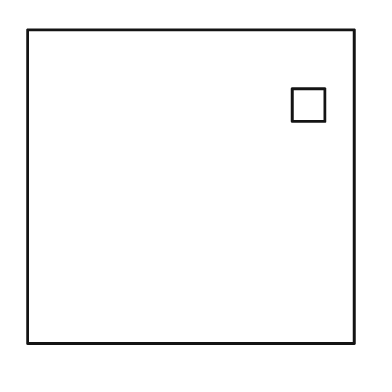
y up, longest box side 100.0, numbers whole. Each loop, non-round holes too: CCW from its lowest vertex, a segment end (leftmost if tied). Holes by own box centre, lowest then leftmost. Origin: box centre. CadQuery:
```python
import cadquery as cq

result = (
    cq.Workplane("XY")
    .moveTo(-50.0, -48.0)
    .lineTo(50.0, -48.0)
    .lineTo(50.0, 48.0)
    .lineTo(-50.0, 48.0)
    .close()
    .moveTo(31.0, 20.0)
    .lineTo(41.0, 20.0)
    .lineTo(41.0, 30.0)
    .lineTo(31.0, 30.0)
    .close()
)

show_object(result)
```